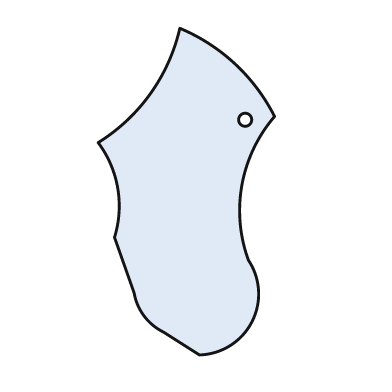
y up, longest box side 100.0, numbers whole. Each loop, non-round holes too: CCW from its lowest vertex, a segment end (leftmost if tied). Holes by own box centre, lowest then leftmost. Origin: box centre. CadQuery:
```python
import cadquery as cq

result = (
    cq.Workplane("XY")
    .moveTo(4.0, -50.0)
    .threePointArc((20.0, -40.0), (19.0, -21.0))
    .threePointArc((17.0, 2.0), (27.0, 23.0))
    .threePointArc((15.0, 39.0), (-2.0, 50.0))
    .threePointArc((-11.0, 30.0), (-27.0, 15.0))
    .threePointArc((-21.0, 1.0), (-22.0, -14.0))
    .lineTo(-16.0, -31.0)
    .threePointArc((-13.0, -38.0), (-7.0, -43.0))
    .close()
    .moveTo(18.0, 22.0)
    .circle(2.0)
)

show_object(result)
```